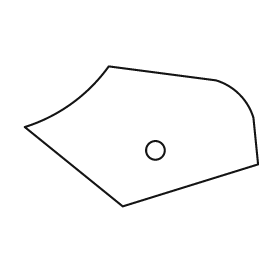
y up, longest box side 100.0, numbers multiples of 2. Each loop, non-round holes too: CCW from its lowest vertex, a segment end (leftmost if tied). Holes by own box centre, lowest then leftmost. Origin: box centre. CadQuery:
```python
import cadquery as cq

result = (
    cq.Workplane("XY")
    .moveTo(-8.0, -30.0)
    .lineTo(50.0, -12.0)
    .lineTo(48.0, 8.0)
    .threePointArc((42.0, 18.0), (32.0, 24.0))
    .lineTo(-14.0, 30.0)
    .threePointArc((-30.0, 14.0), (-50.0, 4.0))
    .close()
    .moveTo(6.0, -6.0)
    .circle(4.0)
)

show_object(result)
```